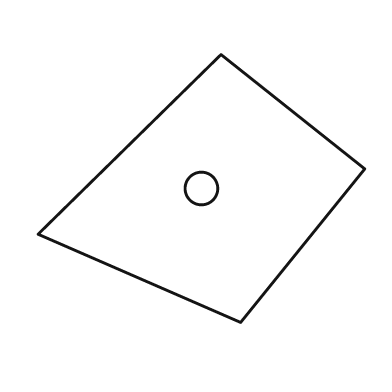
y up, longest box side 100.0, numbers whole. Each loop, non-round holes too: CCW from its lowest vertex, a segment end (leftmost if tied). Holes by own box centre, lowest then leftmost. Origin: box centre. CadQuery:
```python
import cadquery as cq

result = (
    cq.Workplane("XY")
    .moveTo(12.0, -41.0)
    .lineTo(50.0, 6.0)
    .lineTo(6.0, 41.0)
    .lineTo(-50.0, -14.0)
    .close()
    .moveTo(0.0, 0.0)
    .circle(5.0)
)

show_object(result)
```